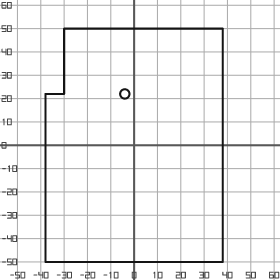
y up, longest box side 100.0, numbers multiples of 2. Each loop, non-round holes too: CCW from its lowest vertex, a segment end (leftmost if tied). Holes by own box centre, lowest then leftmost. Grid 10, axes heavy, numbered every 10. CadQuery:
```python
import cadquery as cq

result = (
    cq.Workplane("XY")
    .moveTo(-38.0, -50.0)
    .lineTo(38.0, -50.0)
    .lineTo(38.0, 50.0)
    .lineTo(-30.0, 50.0)
    .lineTo(-30.0, 22.0)
    .lineTo(-38.0, 22.0)
    .close()
    .moveTo(-4.0, 22.0)
    .circle(2.0)
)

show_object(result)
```